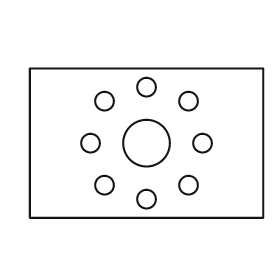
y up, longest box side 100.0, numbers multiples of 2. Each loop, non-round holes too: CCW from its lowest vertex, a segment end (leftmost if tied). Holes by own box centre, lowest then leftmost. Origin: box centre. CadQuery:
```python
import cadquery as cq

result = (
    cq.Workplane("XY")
    .moveTo(-50.0, -32.0)
    .lineTo(50.0, -32.0)
    .lineTo(50.0, 32.0)
    .lineTo(-50.0, 32.0)
    .close()
    .moveTo(0.0, -24.0)
    .circle(4.0)
    .moveTo(-18.0, -18.0)
    .circle(4.0)
    .moveTo(18.0, -18.0)
    .circle(4.0)
    .moveTo(-24.0, 0.0)
    .circle(4.0)
    .moveTo(0.0, 0.0)
    .circle(10.0)
    .moveTo(24.0, 0.0)
    .circle(4.0)
    .moveTo(-18.0, 18.0)
    .circle(4.0)
    .moveTo(18.0, 18.0)
    .circle(4.0)
    .moveTo(0.0, 24.0)
    .circle(4.0)
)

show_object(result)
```